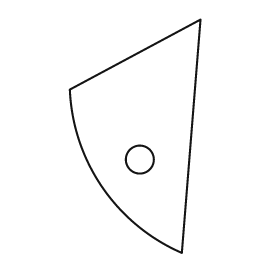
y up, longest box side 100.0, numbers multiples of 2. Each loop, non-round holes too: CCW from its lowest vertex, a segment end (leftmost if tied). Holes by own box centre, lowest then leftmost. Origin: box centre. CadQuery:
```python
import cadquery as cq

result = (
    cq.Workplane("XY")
    .moveTo(20.0, -50.0)
    .lineTo(28.0, 50.0)
    .lineTo(-28.0, 20.0)
    .threePointArc((-14.0, -22.0), (20.0, -50.0))
    .close()
    .moveTo(2.0, -10.0)
    .circle(6.0)
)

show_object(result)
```